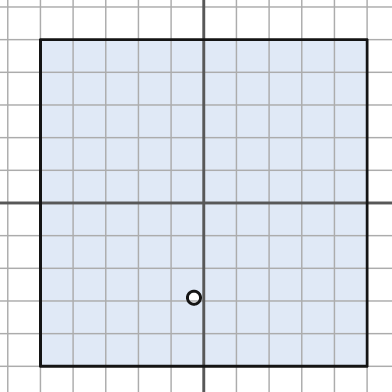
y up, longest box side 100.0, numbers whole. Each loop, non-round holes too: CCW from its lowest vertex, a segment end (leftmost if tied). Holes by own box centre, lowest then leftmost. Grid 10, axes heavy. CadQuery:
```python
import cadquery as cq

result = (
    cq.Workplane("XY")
    .moveTo(-50.0, -50.0)
    .lineTo(50.0, -50.0)
    .lineTo(50.0, 50.0)
    .lineTo(-50.0, 50.0)
    .close()
    .moveTo(-3.0, -29.0)
    .circle(2.0)
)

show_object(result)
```